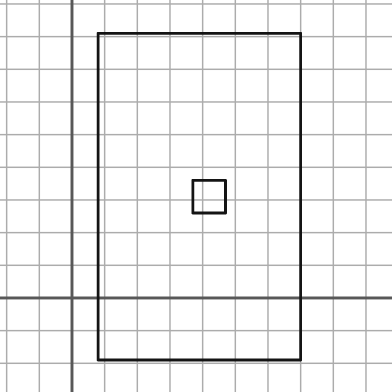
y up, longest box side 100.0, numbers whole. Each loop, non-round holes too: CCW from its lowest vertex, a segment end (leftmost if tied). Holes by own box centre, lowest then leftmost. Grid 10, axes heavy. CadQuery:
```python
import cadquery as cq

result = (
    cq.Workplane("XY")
    .moveTo(8.0, -19.0)
    .lineTo(70.0, -19.0)
    .lineTo(70.0, 81.0)
    .lineTo(8.0, 81.0)
    .close()
    .moveTo(37.0, 26.0)
    .lineTo(47.0, 26.0)
    .lineTo(47.0, 36.0)
    .lineTo(37.0, 36.0)
    .close()
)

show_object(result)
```